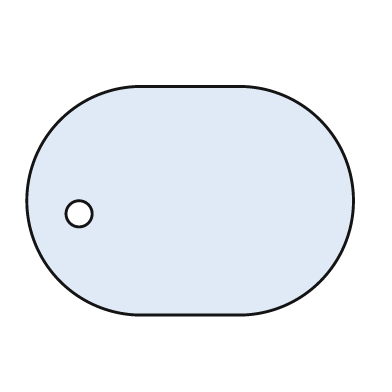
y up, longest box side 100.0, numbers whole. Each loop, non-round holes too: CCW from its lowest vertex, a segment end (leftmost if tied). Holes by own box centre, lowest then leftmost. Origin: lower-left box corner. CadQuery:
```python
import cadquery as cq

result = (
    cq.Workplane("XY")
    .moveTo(35.0, 0.0)
    .lineTo(65.0, 0.0)
    .threePointArc((100.0, 35.0), (65.0, 70.0))
    .lineTo(35.0, 70.0)
    .threePointArc((0.0, 35.0), (35.0, 0.0))
    .close()
    .moveTo(16.0, 31.0)
    .circle(4.0)
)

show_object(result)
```